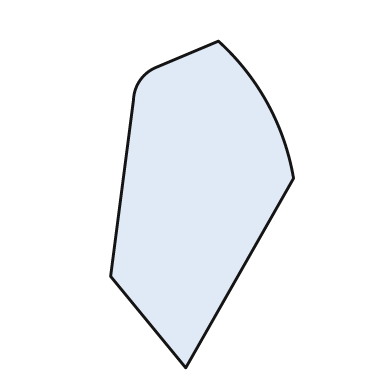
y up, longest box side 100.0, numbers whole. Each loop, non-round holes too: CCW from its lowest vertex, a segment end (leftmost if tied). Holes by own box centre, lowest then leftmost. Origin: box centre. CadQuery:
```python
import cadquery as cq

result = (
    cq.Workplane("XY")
    .moveTo(-5.0, -50.0)
    .lineTo(28.0, 8.0)
    .threePointArc((20.0, 31.0), (5.0, 50.0))
    .lineTo(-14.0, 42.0)
    .threePointArc((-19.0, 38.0), (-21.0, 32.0))
    .lineTo(-28.0, -22.0)
    .close()
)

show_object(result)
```